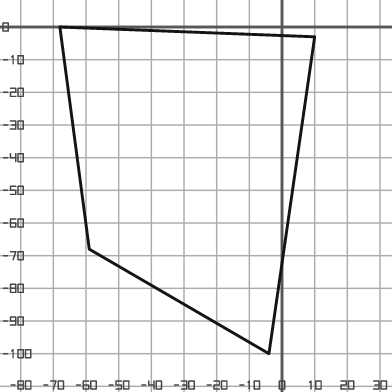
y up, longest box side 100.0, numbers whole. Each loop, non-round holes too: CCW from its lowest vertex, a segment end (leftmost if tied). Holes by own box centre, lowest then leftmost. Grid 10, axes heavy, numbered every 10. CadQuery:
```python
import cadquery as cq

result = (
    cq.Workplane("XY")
    .moveTo(-4.0, -100.0)
    .lineTo(10.0, -3.0)
    .lineTo(-68.0, 0.0)
    .lineTo(-59.0, -68.0)
    .close()
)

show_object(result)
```